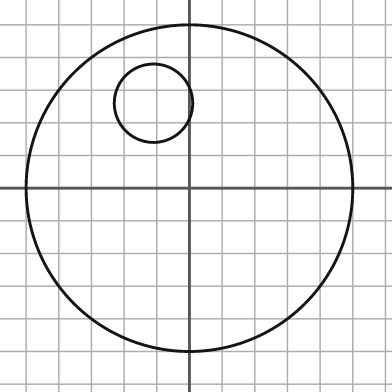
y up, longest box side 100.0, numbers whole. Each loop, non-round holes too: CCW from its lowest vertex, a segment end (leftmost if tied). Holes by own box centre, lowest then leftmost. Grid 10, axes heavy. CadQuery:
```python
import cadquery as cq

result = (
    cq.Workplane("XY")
    .moveTo(0.0, 0.0)
    .circle(50.0)
    .moveTo(-11.0, 26.0)
    .circle(12.0)
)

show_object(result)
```